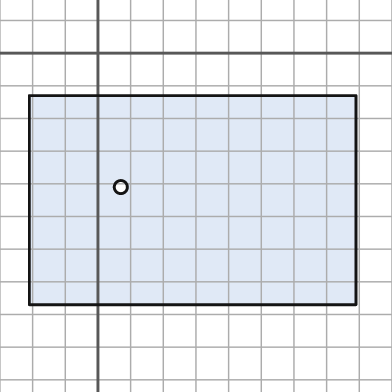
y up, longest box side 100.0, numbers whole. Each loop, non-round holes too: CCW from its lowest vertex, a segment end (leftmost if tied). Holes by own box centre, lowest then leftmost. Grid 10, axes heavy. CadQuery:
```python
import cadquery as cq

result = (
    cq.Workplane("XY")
    .moveTo(-21.0, -77.0)
    .lineTo(79.0, -77.0)
    .lineTo(79.0, -13.0)
    .lineTo(-21.0, -13.0)
    .close()
    .moveTo(7.0, -41.0)
    .circle(2.0)
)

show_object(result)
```